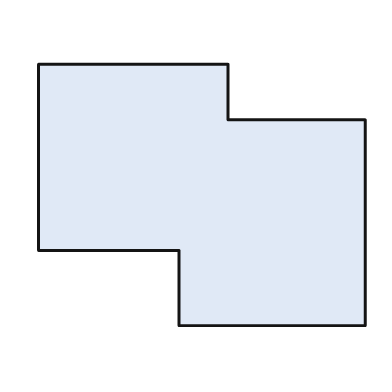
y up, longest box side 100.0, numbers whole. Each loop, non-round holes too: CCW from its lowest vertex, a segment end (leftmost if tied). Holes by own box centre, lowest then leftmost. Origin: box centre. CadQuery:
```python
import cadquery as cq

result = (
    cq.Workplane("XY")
    .moveTo(-7.0, -40.0)
    .lineTo(50.0, -40.0)
    .lineTo(50.0, 23.0)
    .lineTo(8.0, 23.0)
    .lineTo(8.0, 40.0)
    .lineTo(-50.0, 40.0)
    .lineTo(-50.0, -17.0)
    .lineTo(-7.0, -17.0)
    .close()
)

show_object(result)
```